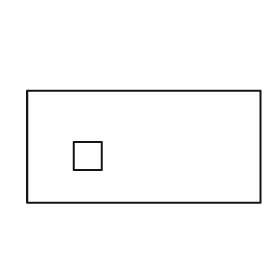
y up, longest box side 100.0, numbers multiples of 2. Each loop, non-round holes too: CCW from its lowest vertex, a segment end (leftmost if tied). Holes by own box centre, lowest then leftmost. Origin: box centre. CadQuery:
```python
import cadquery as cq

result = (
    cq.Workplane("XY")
    .moveTo(-50.0, -24.0)
    .lineTo(50.0, -24.0)
    .lineTo(50.0, 24.0)
    .lineTo(-50.0, 24.0)
    .close()
    .moveTo(-30.0, -10.0)
    .lineTo(-18.0, -10.0)
    .lineTo(-18.0, 2.0)
    .lineTo(-30.0, 2.0)
    .close()
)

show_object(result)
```